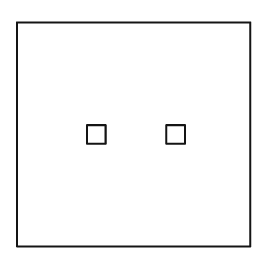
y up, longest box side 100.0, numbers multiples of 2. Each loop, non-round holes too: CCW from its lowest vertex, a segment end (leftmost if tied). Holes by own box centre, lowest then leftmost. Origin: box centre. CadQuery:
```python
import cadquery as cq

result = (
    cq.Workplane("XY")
    .moveTo(-50.0, -48.0)
    .lineTo(50.0, -48.0)
    .lineTo(50.0, 48.0)
    .lineTo(-50.0, 48.0)
    .close()
    .moveTo(-20.0, -4.0)
    .lineTo(-12.0, -4.0)
    .lineTo(-12.0, 4.0)
    .lineTo(-20.0, 4.0)
    .close()
    .moveTo(14.0, -4.0)
    .lineTo(22.0, -4.0)
    .lineTo(22.0, 4.0)
    .lineTo(14.0, 4.0)
    .close()
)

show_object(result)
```